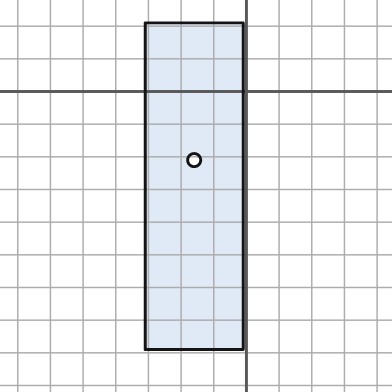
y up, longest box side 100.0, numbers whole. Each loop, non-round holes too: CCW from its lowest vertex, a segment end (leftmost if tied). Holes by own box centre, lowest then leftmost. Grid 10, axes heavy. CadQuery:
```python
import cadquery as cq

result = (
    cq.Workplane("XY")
    .moveTo(-31.0, -79.0)
    .lineTo(-1.0, -79.0)
    .lineTo(-1.0, 21.0)
    .lineTo(-31.0, 21.0)
    .close()
    .moveTo(-16.0, -21.0)
    .circle(2.0)
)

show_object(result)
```